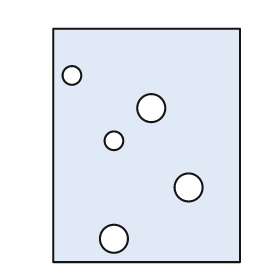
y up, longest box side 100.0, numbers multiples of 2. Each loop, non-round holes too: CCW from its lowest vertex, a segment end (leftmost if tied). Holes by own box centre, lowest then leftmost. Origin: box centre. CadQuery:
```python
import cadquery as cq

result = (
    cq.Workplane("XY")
    .moveTo(-40.0, -50.0)
    .lineTo(40.0, -50.0)
    .lineTo(40.0, 50.0)
    .lineTo(-40.0, 50.0)
    .close()
    .moveTo(-14.0, -40.0)
    .circle(6.0)
    .moveTo(18.0, -18.0)
    .circle(6.0)
    .moveTo(-14.0, 2.0)
    .circle(4.0)
    .moveTo(2.0, 16.0)
    .circle(6.0)
    .moveTo(-32.0, 30.0)
    .circle(4.0)
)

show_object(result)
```